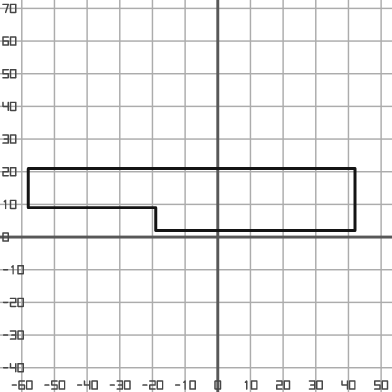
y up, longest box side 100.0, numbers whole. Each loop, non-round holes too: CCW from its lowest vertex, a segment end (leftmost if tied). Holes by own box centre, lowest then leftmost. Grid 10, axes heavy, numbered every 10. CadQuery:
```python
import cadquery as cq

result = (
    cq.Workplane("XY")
    .moveTo(-19.0, 2.0)
    .lineTo(42.0, 2.0)
    .lineTo(42.0, 21.0)
    .lineTo(-58.0, 21.0)
    .lineTo(-58.0, 9.0)
    .lineTo(-19.0, 9.0)
    .close()
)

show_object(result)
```